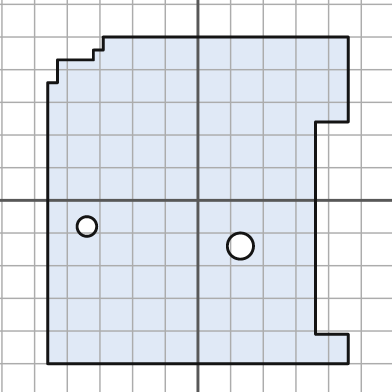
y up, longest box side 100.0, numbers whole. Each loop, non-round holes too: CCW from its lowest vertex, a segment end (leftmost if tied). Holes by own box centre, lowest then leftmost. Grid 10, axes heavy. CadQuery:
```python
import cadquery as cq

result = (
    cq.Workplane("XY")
    .moveTo(-46.0, -50.0)
    .lineTo(46.0, -50.0)
    .lineTo(46.0, -41.0)
    .lineTo(36.0, -41.0)
    .lineTo(36.0, 24.0)
    .lineTo(46.0, 24.0)
    .lineTo(46.0, 50.0)
    .lineTo(-29.0, 50.0)
    .lineTo(-29.0, 46.0)
    .lineTo(-32.0, 46.0)
    .lineTo(-32.0, 43.0)
    .lineTo(-43.0, 43.0)
    .lineTo(-43.0, 36.0)
    .lineTo(-46.0, 36.0)
    .close()
    .moveTo(13.0, -14.0)
    .circle(4.0)
    .moveTo(-34.0, -8.0)
    .circle(3.0)
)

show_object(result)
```